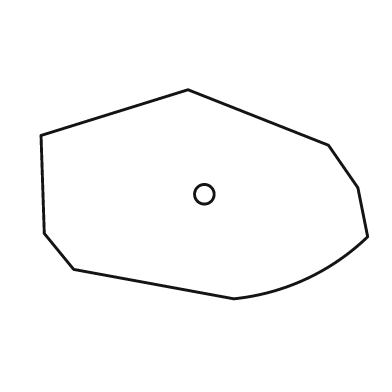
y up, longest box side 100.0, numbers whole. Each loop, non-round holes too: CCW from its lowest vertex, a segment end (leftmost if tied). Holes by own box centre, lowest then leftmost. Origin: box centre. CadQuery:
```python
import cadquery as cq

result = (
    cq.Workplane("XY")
    .moveTo(9.0, -32.0)
    .threePointArc((31.0, -26.0), (50.0, -13.0))
    .lineTo(47.0, 2.0)
    .lineTo(38.0, 15.0)
    .lineTo(-5.0, 32.0)
    .lineTo(-50.0, 18.0)
    .lineTo(-49.0, -12.0)
    .lineTo(-40.0, -23.0)
    .close()
    .moveTo(0.0, 0.0)
    .circle(3.0)
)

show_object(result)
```